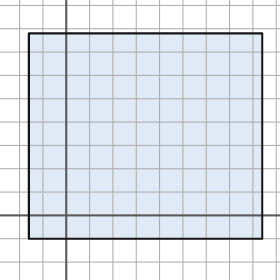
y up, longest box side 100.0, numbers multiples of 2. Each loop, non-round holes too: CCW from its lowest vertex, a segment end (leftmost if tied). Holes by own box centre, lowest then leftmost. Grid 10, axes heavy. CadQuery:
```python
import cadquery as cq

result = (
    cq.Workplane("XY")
    .moveTo(-16.0, -10.0)
    .lineTo(84.0, -10.0)
    .lineTo(84.0, 78.0)
    .lineTo(-16.0, 78.0)
    .close()
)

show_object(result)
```